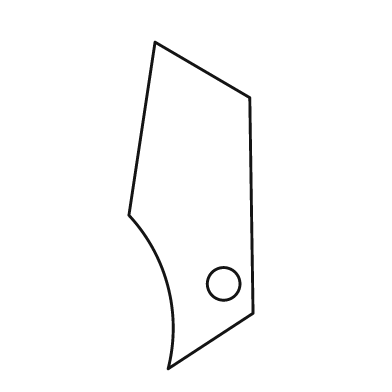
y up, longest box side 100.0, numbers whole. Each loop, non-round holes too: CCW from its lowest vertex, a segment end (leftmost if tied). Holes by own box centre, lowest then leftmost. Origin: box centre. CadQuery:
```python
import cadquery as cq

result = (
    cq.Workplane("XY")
    .moveTo(-7.0, -50.0)
    .lineTo(19.0, -33.0)
    .lineTo(18.0, 33.0)
    .lineTo(-11.0, 50.0)
    .lineTo(-19.0, -3.0)
    .threePointArc((-7.0, -25.0), (-7.0, -50.0))
    .close()
    .moveTo(10.0, -24.0)
    .circle(5.0)
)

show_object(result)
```